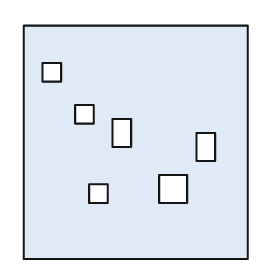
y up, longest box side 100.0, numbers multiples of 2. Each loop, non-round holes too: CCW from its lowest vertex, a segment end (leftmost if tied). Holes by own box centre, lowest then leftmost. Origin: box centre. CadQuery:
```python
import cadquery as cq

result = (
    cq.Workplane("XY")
    .moveTo(-48.0, -50.0)
    .lineTo(48.0, -50.0)
    .lineTo(48.0, 50.0)
    .lineTo(-48.0, 50.0)
    .close()
    .moveTo(-20.0, -26.0)
    .lineTo(-12.0, -26.0)
    .lineTo(-12.0, -18.0)
    .lineTo(-20.0, -18.0)
    .close()
    .moveTo(10.0, -26.0)
    .lineTo(22.0, -26.0)
    .lineTo(22.0, -14.0)
    .lineTo(10.0, -14.0)
    .close()
    .moveTo(26.0, -8.0)
    .lineTo(34.0, -8.0)
    .lineTo(34.0, 4.0)
    .lineTo(26.0, 4.0)
    .close()
    .moveTo(-10.0, -2.0)
    .lineTo(-2.0, -2.0)
    .lineTo(-2.0, 10.0)
    .lineTo(-10.0, 10.0)
    .close()
    .moveTo(-26.0, 8.0)
    .lineTo(-18.0, 8.0)
    .lineTo(-18.0, 16.0)
    .lineTo(-26.0, 16.0)
    .close()
    .moveTo(-40.0, 26.0)
    .lineTo(-32.0, 26.0)
    .lineTo(-32.0, 34.0)
    .lineTo(-40.0, 34.0)
    .close()
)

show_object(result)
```